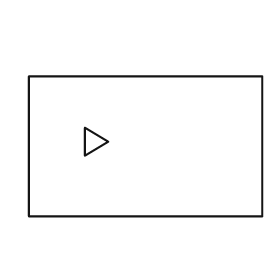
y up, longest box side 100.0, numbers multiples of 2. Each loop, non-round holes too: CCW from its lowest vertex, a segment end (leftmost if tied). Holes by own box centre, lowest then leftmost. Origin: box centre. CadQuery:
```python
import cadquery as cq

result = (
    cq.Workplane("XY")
    .moveTo(-50.0, -30.0)
    .lineTo(50.0, -30.0)
    .lineTo(50.0, 30.0)
    .lineTo(-50.0, 30.0)
    .close()
    .moveTo(-26.0, -4.0)
    .lineTo(-16.0, 2.0)
    .lineTo(-26.0, 8.0)
    .close()
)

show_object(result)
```